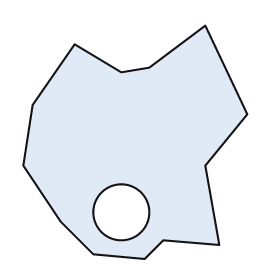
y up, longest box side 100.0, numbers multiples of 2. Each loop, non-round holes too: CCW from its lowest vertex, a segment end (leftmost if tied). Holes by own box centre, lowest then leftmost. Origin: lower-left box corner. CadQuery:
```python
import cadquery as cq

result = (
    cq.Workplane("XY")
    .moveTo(52.0, 0.0)
    .lineTo(60.0, 8.0)
    .lineTo(84.0, 6.0)
    .lineTo(78.0, 40.0)
    .lineTo(96.0, 62.0)
    .lineTo(78.0, 100.0)
    .lineTo(54.0, 82.0)
    .lineTo(42.0, 80.0)
    .lineTo(22.0, 92.0)
    .lineTo(4.0, 66.0)
    .lineTo(0.0, 40.0)
    .lineTo(16.0, 16.0)
    .lineTo(30.0, 2.0)
    .close()
    .moveTo(42.0, 20.0)
    .circle(12.0)
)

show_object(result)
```